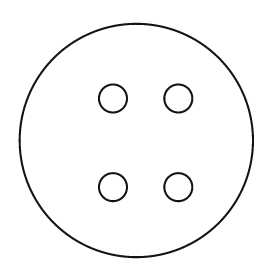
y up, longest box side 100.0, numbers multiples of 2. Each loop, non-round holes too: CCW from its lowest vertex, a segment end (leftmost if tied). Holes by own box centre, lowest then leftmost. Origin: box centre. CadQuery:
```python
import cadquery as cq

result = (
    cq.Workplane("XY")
    .moveTo(0.0, 0.0)
    .circle(50.0)
    .moveTo(-10.0, -20.0)
    .circle(6.0)
    .moveTo(18.0, -20.0)
    .circle(6.0)
    .moveTo(-10.0, 18.0)
    .circle(6.0)
    .moveTo(18.0, 18.0)
    .circle(6.0)
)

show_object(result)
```